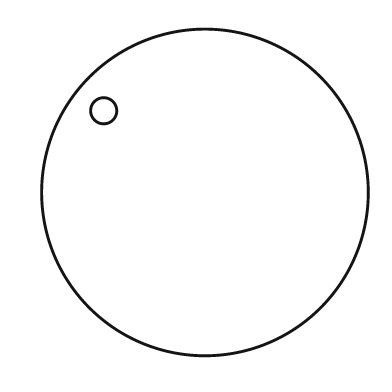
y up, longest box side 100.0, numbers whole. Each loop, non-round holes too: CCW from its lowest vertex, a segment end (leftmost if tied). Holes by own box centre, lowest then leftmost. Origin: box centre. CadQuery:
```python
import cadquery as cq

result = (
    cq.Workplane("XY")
    .moveTo(0.0, 0.0)
    .circle(50.0)
    .moveTo(-31.0, 25.0)
    .circle(4.0)
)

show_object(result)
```